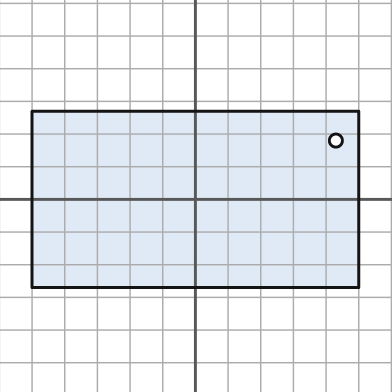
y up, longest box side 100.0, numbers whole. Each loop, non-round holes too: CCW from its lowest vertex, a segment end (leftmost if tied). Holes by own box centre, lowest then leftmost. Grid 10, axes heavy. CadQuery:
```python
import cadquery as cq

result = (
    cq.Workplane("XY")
    .moveTo(-50.0, -27.0)
    .lineTo(50.0, -27.0)
    .lineTo(50.0, 27.0)
    .lineTo(-50.0, 27.0)
    .close()
    .moveTo(43.0, 18.0)
    .circle(2.0)
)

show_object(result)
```